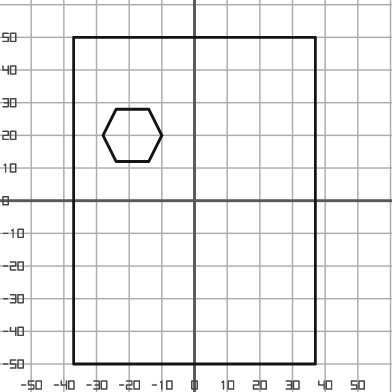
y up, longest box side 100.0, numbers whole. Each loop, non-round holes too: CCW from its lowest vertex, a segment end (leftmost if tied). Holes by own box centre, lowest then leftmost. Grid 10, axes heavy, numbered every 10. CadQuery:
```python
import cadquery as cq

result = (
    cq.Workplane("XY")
    .moveTo(-37.0, -50.0)
    .lineTo(37.0, -50.0)
    .lineTo(37.0, 50.0)
    .lineTo(-37.0, 50.0)
    .close()
    .moveTo(-24.0, 12.0)
    .lineTo(-14.0, 12.0)
    .lineTo(-10.0, 20.0)
    .lineTo(-14.0, 28.0)
    .lineTo(-24.0, 28.0)
    .lineTo(-28.0, 20.0)
    .close()
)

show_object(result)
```